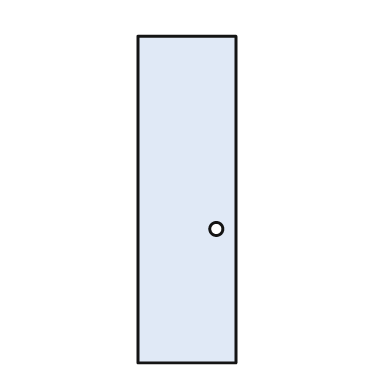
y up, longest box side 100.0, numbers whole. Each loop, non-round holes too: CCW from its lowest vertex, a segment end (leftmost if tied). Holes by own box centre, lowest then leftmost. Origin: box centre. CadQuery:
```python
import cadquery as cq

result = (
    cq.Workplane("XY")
    .moveTo(-15.0, -50.0)
    .lineTo(15.0, -50.0)
    .lineTo(15.0, 50.0)
    .lineTo(-15.0, 50.0)
    .close()
    .moveTo(9.0, -9.0)
    .circle(2.0)
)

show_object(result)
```